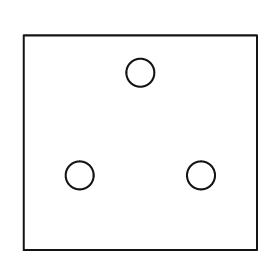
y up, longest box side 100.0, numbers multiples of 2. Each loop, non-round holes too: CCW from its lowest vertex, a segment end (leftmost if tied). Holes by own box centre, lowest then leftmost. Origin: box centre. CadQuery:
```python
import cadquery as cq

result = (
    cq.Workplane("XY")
    .moveTo(-50.0, -46.0)
    .lineTo(50.0, -46.0)
    .lineTo(50.0, 46.0)
    .lineTo(-50.0, 46.0)
    .close()
    .moveTo(-26.0, -14.0)
    .circle(6.0)
    .moveTo(26.0, -14.0)
    .circle(6.0)
    .moveTo(0.0, 30.0)
    .circle(6.0)
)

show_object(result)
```